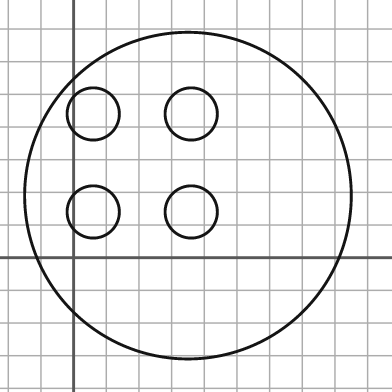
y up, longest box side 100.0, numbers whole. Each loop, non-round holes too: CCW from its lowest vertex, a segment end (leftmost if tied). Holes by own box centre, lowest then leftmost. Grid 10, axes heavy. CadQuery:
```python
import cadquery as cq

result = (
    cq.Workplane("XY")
    .moveTo(35.0, 19.0)
    .circle(50.0)
    .moveTo(6.0, 14.0)
    .circle(8.0)
    .moveTo(36.0, 14.0)
    .circle(8.0)
    .moveTo(6.0, 44.0)
    .circle(8.0)
    .moveTo(36.0, 44.0)
    .circle(8.0)
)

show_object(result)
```